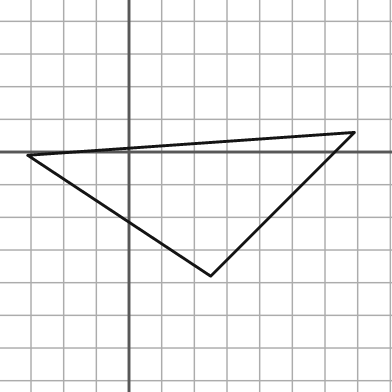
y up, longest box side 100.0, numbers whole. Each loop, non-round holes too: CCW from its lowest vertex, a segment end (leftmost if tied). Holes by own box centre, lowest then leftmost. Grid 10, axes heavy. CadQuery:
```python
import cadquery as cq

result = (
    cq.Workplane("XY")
    .moveTo(25.0, -38.0)
    .lineTo(69.0, 6.0)
    .lineTo(-31.0, -1.0)
    .close()
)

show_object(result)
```